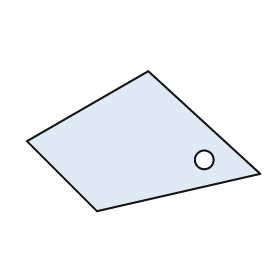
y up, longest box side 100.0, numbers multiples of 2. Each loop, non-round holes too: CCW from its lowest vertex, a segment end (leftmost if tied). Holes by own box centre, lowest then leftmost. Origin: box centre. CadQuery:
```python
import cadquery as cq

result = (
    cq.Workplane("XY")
    .moveTo(-20.0, -30.0)
    .lineTo(50.0, -14.0)
    .lineTo(2.0, 30.0)
    .lineTo(-50.0, 0.0)
    .close()
    .moveTo(26.0, -8.0)
    .circle(4.0)
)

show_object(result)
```